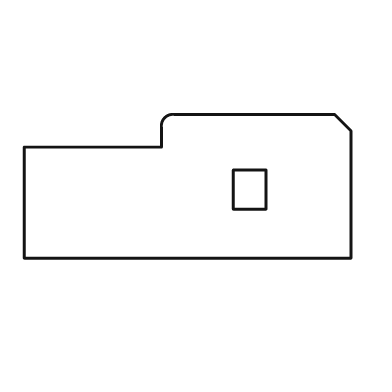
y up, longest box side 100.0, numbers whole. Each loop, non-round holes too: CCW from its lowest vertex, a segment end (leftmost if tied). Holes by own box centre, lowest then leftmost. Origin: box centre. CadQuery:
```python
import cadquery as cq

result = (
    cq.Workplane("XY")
    .moveTo(-50.0, -22.0)
    .lineTo(50.0, -22.0)
    .lineTo(50.0, 17.0)
    .lineTo(45.0, 22.0)
    .lineTo(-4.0, 22.0)
    .threePointArc((-7.0, 21.0), (-8.0, 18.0))
    .lineTo(-8.0, 12.0)
    .lineTo(-50.0, 12.0)
    .close()
    .moveTo(14.0, -7.0)
    .lineTo(24.0, -7.0)
    .lineTo(24.0, 5.0)
    .lineTo(14.0, 5.0)
    .close()
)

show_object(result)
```